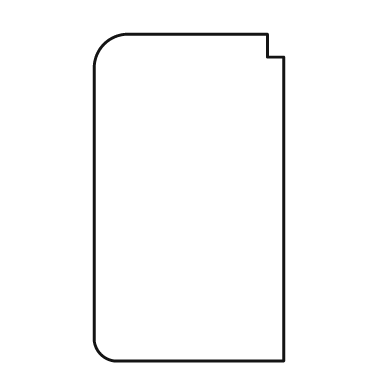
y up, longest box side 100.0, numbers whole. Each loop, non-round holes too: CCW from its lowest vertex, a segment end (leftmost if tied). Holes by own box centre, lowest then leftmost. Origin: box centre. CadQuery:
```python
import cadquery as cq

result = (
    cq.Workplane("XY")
    .moveTo(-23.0, -50.0)
    .lineTo(29.0, -50.0)
    .lineTo(29.0, 43.0)
    .lineTo(24.0, 43.0)
    .lineTo(24.0, 50.0)
    .lineTo(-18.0, 50.0)
    .threePointArc((-26.0, 47.0), (-29.0, 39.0))
    .lineTo(-29.0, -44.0)
    .threePointArc((-27.0, -48.0), (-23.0, -50.0))
    .close()
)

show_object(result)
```